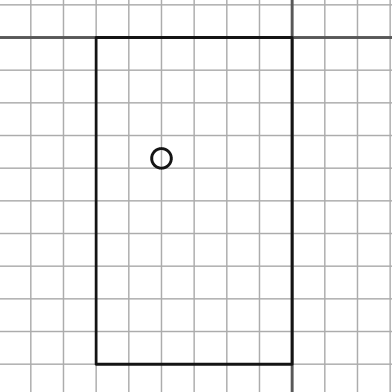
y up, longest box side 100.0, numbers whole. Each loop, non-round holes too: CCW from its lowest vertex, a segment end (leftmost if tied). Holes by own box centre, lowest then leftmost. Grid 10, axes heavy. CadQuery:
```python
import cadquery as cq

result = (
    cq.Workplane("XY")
    .moveTo(-60.0, -100.0)
    .lineTo(0.0, -100.0)
    .lineTo(0.0, 0.0)
    .lineTo(-60.0, 0.0)
    .close()
    .moveTo(-40.0, -37.0)
    .circle(3.0)
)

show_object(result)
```